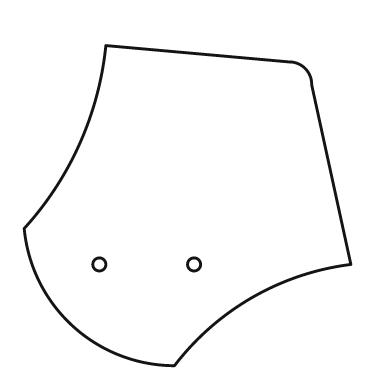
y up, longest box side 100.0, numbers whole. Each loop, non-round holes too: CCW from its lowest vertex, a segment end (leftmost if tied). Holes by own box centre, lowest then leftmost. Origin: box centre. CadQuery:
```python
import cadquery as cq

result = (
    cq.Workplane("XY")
    .moveTo(-4.0, -49.0)
    .threePointArc((20.0, -28.0), (50.0, -18.0))
    .lineTo(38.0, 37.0)
    .threePointArc((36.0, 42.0), (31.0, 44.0))
    .lineTo(-25.0, 49.0)
    .threePointArc((-33.0, 19.0), (-50.0, -7.0))
    .threePointArc((-35.0, -37.0), (-4.0, -49.0))
    .close()
    .moveTo(-27.0, -18.0)
    .circle(2.0)
    .moveTo(2.0, -18.0)
    .circle(2.0)
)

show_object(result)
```